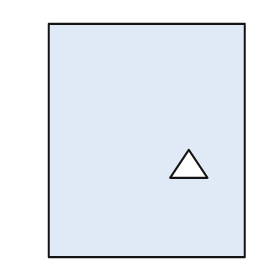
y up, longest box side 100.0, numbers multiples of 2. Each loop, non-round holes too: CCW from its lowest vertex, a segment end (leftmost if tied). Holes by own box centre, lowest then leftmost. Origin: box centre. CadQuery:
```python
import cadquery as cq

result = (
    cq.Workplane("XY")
    .moveTo(-42.0, -50.0)
    .lineTo(42.0, -50.0)
    .lineTo(42.0, 50.0)
    .lineTo(-42.0, 50.0)
    .close()
    .moveTo(10.0, -16.0)
    .lineTo(26.0, -16.0)
    .lineTo(18.0, -4.0)
    .close()
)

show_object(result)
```